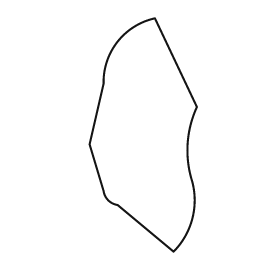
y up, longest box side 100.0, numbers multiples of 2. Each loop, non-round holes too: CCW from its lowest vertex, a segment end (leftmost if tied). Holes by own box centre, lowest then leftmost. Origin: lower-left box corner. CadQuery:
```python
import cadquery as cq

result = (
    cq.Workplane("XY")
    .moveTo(36.0, 0.0)
    .threePointArc((44.0, 14.0), (44.0, 30.0))
    .threePointArc((42.0, 46.0), (46.0, 62.0))
    .lineTo(28.0, 100.0)
    .threePointArc((12.0, 90.0), (6.0, 72.0))
    .lineTo(0.0, 46.0)
    .lineTo(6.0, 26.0)
    .threePointArc((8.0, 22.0), (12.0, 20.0))
    .close()
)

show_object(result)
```